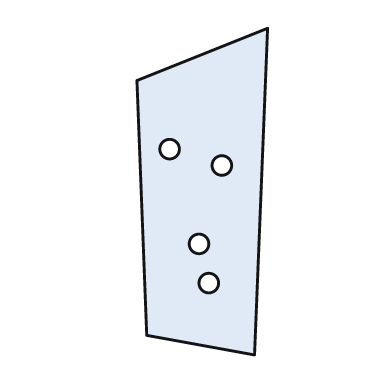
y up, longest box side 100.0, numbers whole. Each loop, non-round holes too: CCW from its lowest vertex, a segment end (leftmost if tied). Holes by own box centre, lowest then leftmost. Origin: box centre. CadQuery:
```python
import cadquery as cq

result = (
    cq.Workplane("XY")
    .moveTo(16.0, -50.0)
    .lineTo(20.0, 50.0)
    .lineTo(-20.0, 34.0)
    .lineTo(-17.0, -44.0)
    .close()
    .moveTo(2.0, -28.0)
    .circle(3.0)
    .moveTo(-1.0, -16.0)
    .circle(3.0)
    .moveTo(6.0, 8.0)
    .circle(3.0)
    .moveTo(-10.0, 13.0)
    .circle(3.0)
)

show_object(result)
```